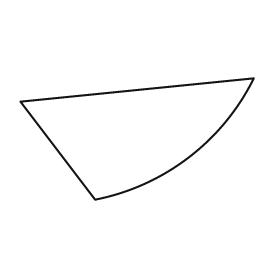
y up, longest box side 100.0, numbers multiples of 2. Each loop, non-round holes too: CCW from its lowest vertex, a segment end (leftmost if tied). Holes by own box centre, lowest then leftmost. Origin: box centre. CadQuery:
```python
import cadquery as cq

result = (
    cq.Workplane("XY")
    .moveTo(-18.0, -26.0)
    .threePointArc((22.0, -8.0), (50.0, 26.0))
    .lineTo(-50.0, 16.0)
    .close()
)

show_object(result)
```